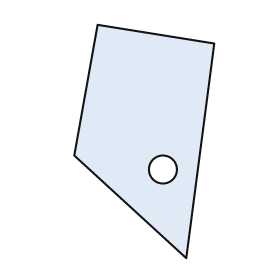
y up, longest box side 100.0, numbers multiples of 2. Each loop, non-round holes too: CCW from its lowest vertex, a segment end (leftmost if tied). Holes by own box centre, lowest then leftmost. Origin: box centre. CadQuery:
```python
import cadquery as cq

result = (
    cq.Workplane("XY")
    .moveTo(18.0, -50.0)
    .lineTo(30.0, 42.0)
    .lineTo(-20.0, 50.0)
    .lineTo(-30.0, -6.0)
    .close()
    .moveTo(8.0, -12.0)
    .circle(6.0)
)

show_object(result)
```